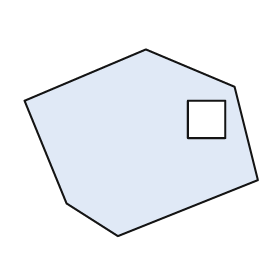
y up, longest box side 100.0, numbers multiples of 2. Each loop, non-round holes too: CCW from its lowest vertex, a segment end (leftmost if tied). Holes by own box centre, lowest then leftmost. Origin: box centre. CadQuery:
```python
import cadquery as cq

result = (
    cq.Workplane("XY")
    .moveTo(-10.0, -40.0)
    .lineTo(50.0, -16.0)
    .lineTo(40.0, 24.0)
    .lineTo(2.0, 40.0)
    .lineTo(-50.0, 18.0)
    .lineTo(-32.0, -26.0)
    .close()
    .moveTo(20.0, 2.0)
    .lineTo(36.0, 2.0)
    .lineTo(36.0, 18.0)
    .lineTo(20.0, 18.0)
    .close()
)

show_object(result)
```